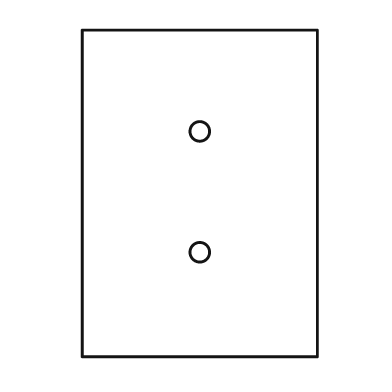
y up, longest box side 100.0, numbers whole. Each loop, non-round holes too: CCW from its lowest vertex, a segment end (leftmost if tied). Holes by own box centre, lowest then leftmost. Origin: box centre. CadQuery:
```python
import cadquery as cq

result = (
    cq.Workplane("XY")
    .moveTo(-36.0, -50.0)
    .lineTo(36.0, -50.0)
    .lineTo(36.0, 50.0)
    .lineTo(-36.0, 50.0)
    .close()
    .moveTo(0.0, -18.0)
    .circle(3.0)
    .moveTo(0.0, 19.0)
    .circle(3.0)
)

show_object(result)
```